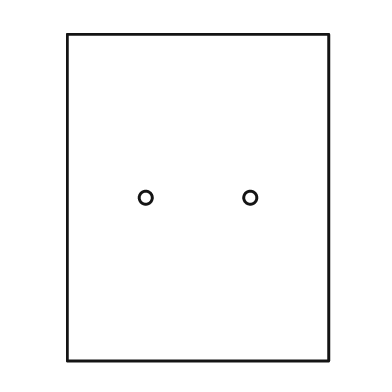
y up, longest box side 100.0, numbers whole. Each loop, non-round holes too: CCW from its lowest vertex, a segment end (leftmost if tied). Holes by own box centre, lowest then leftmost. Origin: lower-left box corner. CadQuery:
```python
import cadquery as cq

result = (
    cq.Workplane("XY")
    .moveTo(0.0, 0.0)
    .lineTo(80.0, 0.0)
    .lineTo(80.0, 100.0)
    .lineTo(0.0, 100.0)
    .close()
    .moveTo(24.0, 50.0)
    .circle(2.0)
    .moveTo(56.0, 50.0)
    .circle(2.0)
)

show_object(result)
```